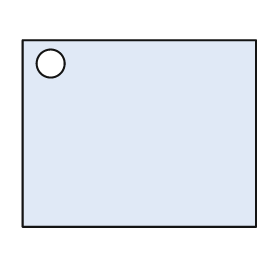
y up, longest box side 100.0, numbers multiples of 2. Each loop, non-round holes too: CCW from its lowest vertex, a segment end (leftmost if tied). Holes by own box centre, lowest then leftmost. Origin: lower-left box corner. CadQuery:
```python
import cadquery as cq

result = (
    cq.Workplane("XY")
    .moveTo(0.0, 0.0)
    .lineTo(100.0, 0.0)
    .lineTo(100.0, 80.0)
    .lineTo(0.0, 80.0)
    .close()
    .moveTo(12.0, 70.0)
    .circle(6.0)
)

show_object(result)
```